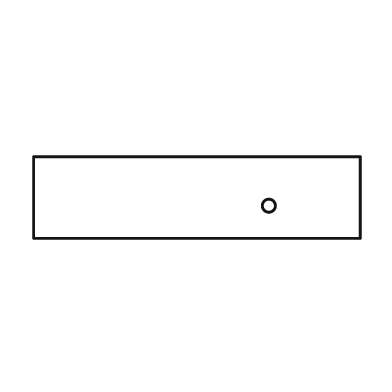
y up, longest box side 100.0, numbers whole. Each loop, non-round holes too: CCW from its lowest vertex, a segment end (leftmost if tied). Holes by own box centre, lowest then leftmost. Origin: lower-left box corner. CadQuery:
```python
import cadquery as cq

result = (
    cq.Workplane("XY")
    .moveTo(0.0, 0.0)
    .lineTo(100.0, 0.0)
    .lineTo(100.0, 25.0)
    .lineTo(0.0, 25.0)
    .close()
    .moveTo(72.0, 10.0)
    .circle(2.0)
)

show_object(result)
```